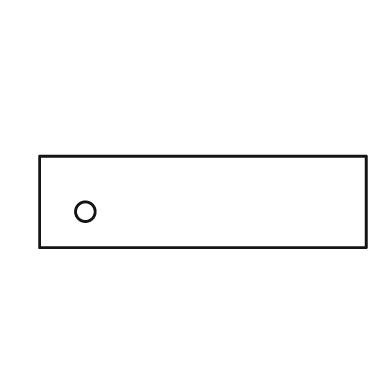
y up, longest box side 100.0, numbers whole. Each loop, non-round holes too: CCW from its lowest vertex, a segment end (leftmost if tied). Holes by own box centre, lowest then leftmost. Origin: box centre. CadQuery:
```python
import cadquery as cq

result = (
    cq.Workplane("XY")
    .moveTo(-50.0, -14.0)
    .lineTo(50.0, -14.0)
    .lineTo(50.0, 14.0)
    .lineTo(-50.0, 14.0)
    .close()
    .moveTo(-36.0, -3.0)
    .circle(3.0)
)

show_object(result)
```